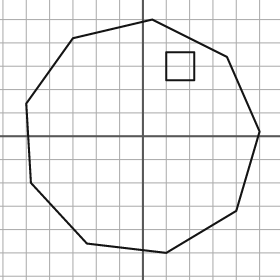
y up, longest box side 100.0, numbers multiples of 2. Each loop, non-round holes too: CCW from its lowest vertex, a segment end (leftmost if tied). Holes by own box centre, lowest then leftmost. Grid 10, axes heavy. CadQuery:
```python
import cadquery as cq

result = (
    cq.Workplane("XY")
    .moveTo(10.0, -50.0)
    .lineTo(40.0, -32.0)
    .lineTo(50.0, 2.0)
    .lineTo(36.0, 34.0)
    .lineTo(4.0, 50.0)
    .lineTo(-30.0, 42.0)
    .lineTo(-50.0, 14.0)
    .lineTo(-48.0, -20.0)
    .lineTo(-24.0, -46.0)
    .close()
    .moveTo(10.0, 24.0)
    .lineTo(22.0, 24.0)
    .lineTo(22.0, 36.0)
    .lineTo(10.0, 36.0)
    .close()
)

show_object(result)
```